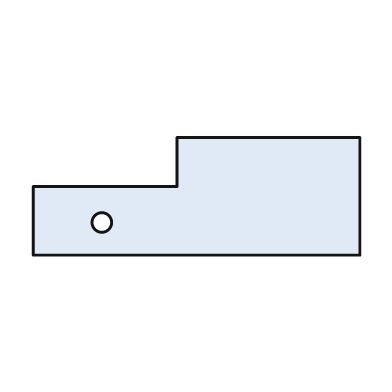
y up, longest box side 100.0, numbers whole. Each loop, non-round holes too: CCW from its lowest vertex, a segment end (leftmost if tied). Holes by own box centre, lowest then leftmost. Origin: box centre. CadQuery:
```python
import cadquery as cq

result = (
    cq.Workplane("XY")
    .moveTo(-50.0, -18.0)
    .lineTo(50.0, -18.0)
    .lineTo(50.0, 18.0)
    .lineTo(-6.0, 18.0)
    .lineTo(-6.0, 3.0)
    .lineTo(-50.0, 3.0)
    .close()
    .moveTo(-29.0, -8.0)
    .circle(3.0)
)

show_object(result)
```